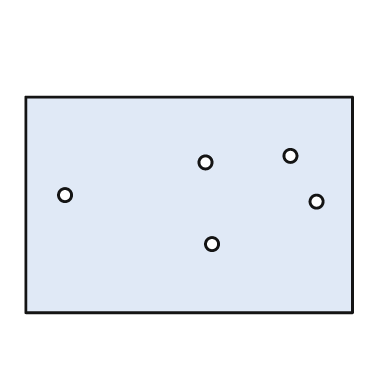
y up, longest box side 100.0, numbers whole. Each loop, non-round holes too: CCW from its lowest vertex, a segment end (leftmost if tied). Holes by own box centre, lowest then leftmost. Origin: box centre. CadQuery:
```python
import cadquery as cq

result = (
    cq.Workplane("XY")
    .moveTo(-50.0, -33.0)
    .lineTo(50.0, -33.0)
    .lineTo(50.0, 33.0)
    .lineTo(-50.0, 33.0)
    .close()
    .moveTo(7.0, -12.0)
    .circle(2.0)
    .moveTo(39.0, 1.0)
    .circle(2.0)
    .moveTo(-38.0, 3.0)
    .circle(2.0)
    .moveTo(5.0, 13.0)
    .circle(2.0)
    .moveTo(31.0, 15.0)
    .circle(2.0)
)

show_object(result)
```